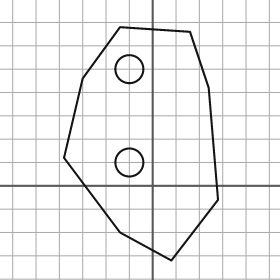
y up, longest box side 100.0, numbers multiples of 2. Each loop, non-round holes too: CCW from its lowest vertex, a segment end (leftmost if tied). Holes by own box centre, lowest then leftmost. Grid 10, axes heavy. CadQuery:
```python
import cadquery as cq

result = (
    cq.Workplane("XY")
    .moveTo(8.0, -32.0)
    .lineTo(28.0, -6.0)
    .lineTo(24.0, 42.0)
    .lineTo(16.0, 66.0)
    .lineTo(-14.0, 68.0)
    .lineTo(-30.0, 46.0)
    .lineTo(-38.0, 12.0)
    .lineTo(-14.0, -20.0)
    .close()
    .moveTo(-10.0, 10.0)
    .circle(6.0)
    .moveTo(-10.0, 50.0)
    .circle(6.0)
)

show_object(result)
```